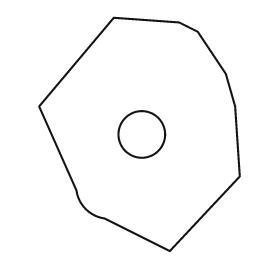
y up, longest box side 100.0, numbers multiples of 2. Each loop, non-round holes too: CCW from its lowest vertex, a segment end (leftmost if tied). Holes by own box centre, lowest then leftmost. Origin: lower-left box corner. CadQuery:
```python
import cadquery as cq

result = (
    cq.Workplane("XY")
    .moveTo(56.0, 0.0)
    .lineTo(86.0, 32.0)
    .lineTo(84.0, 62.0)
    .lineTo(80.0, 76.0)
    .lineTo(68.0, 94.0)
    .lineTo(60.0, 98.0)
    .lineTo(32.0, 100.0)
    .lineTo(0.0, 62.0)
    .lineTo(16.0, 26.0)
    .threePointArc((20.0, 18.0), (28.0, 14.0))
    .close()
    .moveTo(44.0, 50.0)
    .circle(10.0)
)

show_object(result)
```